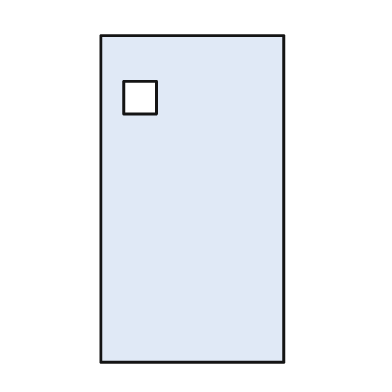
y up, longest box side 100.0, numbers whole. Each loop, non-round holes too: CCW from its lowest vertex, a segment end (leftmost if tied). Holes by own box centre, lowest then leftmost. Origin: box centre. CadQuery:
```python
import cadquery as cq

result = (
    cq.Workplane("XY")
    .moveTo(-28.0, -50.0)
    .lineTo(28.0, -50.0)
    .lineTo(28.0, 50.0)
    .lineTo(-28.0, 50.0)
    .close()
    .moveTo(-21.0, 26.0)
    .lineTo(-11.0, 26.0)
    .lineTo(-11.0, 36.0)
    .lineTo(-21.0, 36.0)
    .close()
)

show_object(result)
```